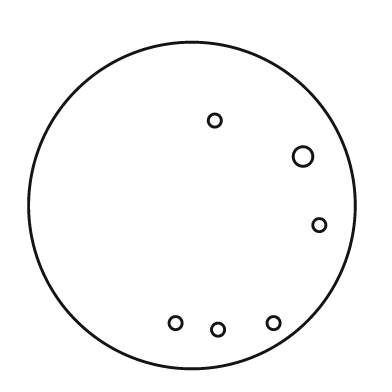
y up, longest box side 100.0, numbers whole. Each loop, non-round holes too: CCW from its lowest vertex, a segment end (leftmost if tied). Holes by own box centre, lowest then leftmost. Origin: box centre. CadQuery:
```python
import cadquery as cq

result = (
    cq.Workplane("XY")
    .moveTo(0.0, 0.0)
    .circle(50.0)
    .moveTo(8.0, -38.0)
    .circle(2.0)
    .moveTo(-5.0, -36.0)
    .circle(2.0)
    .moveTo(25.0, -36.0)
    .circle(2.0)
    .moveTo(39.0, -6.0)
    .circle(2.0)
    .moveTo(34.0, 15.0)
    .circle(3.0)
    .moveTo(7.0, 26.0)
    .circle(2.0)
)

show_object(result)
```